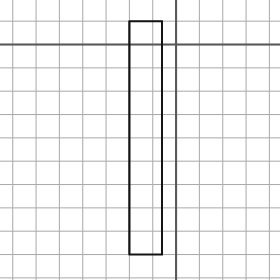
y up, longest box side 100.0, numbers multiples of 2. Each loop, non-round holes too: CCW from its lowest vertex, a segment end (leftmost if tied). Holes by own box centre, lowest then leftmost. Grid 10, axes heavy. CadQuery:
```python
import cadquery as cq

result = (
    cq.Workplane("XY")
    .moveTo(-20.0, -90.0)
    .lineTo(-6.0, -90.0)
    .lineTo(-6.0, 10.0)
    .lineTo(-20.0, 10.0)
    .close()
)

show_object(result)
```